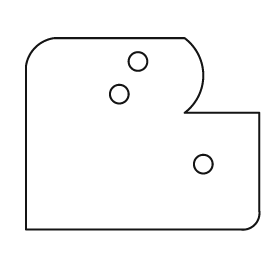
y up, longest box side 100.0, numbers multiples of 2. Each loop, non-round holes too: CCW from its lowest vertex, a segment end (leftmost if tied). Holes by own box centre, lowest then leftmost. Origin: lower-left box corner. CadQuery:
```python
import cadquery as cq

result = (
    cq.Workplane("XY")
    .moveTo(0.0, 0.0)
    .lineTo(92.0, 0.0)
    .threePointArc((98.0, 2.0), (100.0, 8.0))
    .lineTo(100.0, 50.0)
    .lineTo(68.0, 50.0)
    .threePointArc((76.0, 66.0), (68.0, 82.0))
    .lineTo(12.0, 82.0)
    .threePointArc((4.0, 78.0), (0.0, 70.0))
    .close()
    .moveTo(76.0, 28.0)
    .circle(4.0)
    .moveTo(40.0, 58.0)
    .circle(4.0)
    .moveTo(48.0, 72.0)
    .circle(4.0)
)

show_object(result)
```